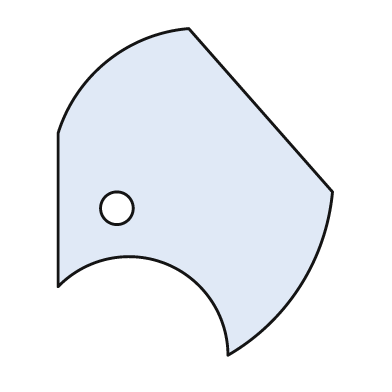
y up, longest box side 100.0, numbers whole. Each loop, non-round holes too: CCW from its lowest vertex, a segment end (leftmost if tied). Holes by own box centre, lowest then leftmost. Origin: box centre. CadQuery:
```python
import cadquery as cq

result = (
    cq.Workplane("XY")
    .moveTo(10.0, -50.0)
    .threePointArc((32.0, -29.0), (42.0, 0.0))
    .lineTo(-2.0, 50.0)
    .threePointArc((-27.0, 40.0), (-42.0, 18.0))
    .lineTo(-42.0, -29.0)
    .threePointArc((-9.0, -22.0), (10.0, -50.0))
    .close()
    .moveTo(-24.0, -5.0)
    .circle(5.0)
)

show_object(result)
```